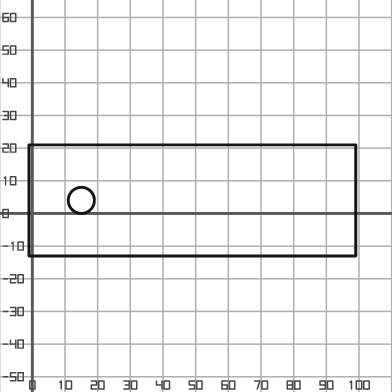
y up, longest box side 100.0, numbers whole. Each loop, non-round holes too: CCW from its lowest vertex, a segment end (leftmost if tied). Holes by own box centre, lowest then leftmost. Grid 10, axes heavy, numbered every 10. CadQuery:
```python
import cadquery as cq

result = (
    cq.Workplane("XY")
    .moveTo(-1.0, -13.0)
    .lineTo(99.0, -13.0)
    .lineTo(99.0, 21.0)
    .lineTo(-1.0, 21.0)
    .close()
    .moveTo(15.0, 4.0)
    .circle(4.0)
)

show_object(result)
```